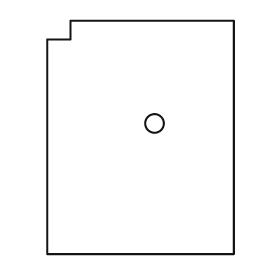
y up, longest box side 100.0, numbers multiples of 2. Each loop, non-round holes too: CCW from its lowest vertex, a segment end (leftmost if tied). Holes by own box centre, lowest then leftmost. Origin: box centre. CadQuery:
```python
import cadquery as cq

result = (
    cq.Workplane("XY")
    .moveTo(-40.0, -50.0)
    .lineTo(40.0, -50.0)
    .lineTo(40.0, 50.0)
    .lineTo(-30.0, 50.0)
    .lineTo(-30.0, 42.0)
    .lineTo(-40.0, 42.0)
    .close()
    .moveTo(6.0, 6.0)
    .circle(4.0)
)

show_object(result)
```